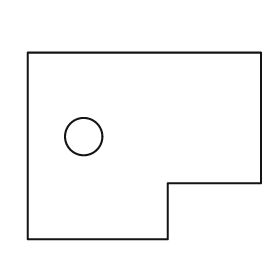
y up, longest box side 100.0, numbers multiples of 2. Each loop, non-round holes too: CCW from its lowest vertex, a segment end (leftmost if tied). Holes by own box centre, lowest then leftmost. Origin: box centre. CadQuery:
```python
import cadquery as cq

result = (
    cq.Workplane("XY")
    .moveTo(-50.0, -40.0)
    .lineTo(10.0, -40.0)
    .lineTo(10.0, -16.0)
    .lineTo(50.0, -16.0)
    .lineTo(50.0, 40.0)
    .lineTo(-50.0, 40.0)
    .close()
    .moveTo(-26.0, 4.0)
    .circle(8.0)
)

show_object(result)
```